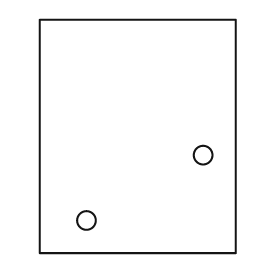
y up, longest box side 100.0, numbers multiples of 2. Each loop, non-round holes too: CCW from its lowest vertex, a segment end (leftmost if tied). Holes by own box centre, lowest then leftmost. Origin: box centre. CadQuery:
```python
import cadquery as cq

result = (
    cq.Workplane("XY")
    .moveTo(-42.0, -50.0)
    .lineTo(42.0, -50.0)
    .lineTo(42.0, 50.0)
    .lineTo(-42.0, 50.0)
    .close()
    .moveTo(-22.0, -36.0)
    .circle(4.0)
    .moveTo(28.0, -8.0)
    .circle(4.0)
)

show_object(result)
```